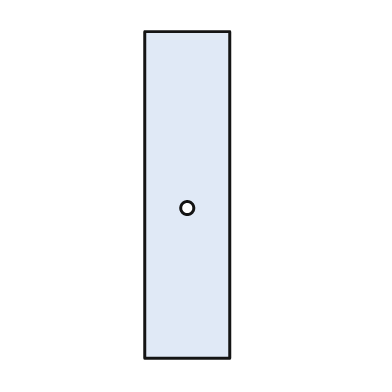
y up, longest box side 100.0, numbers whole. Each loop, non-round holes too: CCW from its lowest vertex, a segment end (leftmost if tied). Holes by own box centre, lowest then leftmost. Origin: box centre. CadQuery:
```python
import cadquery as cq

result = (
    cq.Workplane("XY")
    .moveTo(-13.0, -50.0)
    .lineTo(13.0, -50.0)
    .lineTo(13.0, 50.0)
    .lineTo(-13.0, 50.0)
    .close()
    .moveTo(0.0, -4.0)
    .circle(2.0)
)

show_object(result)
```